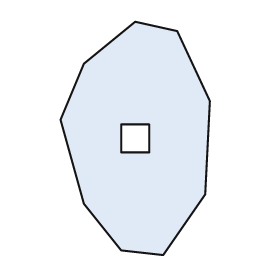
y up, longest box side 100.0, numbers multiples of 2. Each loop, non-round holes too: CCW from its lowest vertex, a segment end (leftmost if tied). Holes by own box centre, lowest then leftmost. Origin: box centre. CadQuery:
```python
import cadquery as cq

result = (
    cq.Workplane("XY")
    .moveTo(12.0, -50.0)
    .lineTo(30.0, -24.0)
    .lineTo(32.0, 16.0)
    .lineTo(18.0, 46.0)
    .lineTo(0.0, 50.0)
    .lineTo(-22.0, 32.0)
    .lineTo(-32.0, 8.0)
    .lineTo(-22.0, -28.0)
    .lineTo(-6.0, -48.0)
    .close()
    .moveTo(-6.0, -6.0)
    .lineTo(6.0, -6.0)
    .lineTo(6.0, 6.0)
    .lineTo(-6.0, 6.0)
    .close()
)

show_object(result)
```